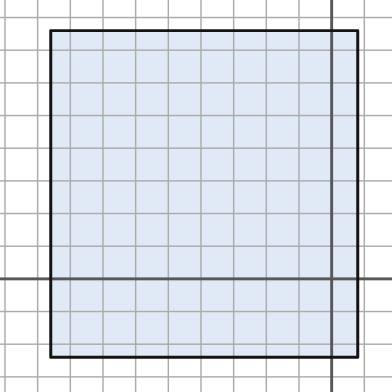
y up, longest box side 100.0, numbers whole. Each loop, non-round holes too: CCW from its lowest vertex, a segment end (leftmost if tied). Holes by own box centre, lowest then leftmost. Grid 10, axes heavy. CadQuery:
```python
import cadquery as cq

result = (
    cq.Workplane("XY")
    .moveTo(-86.0, -24.0)
    .lineTo(8.0, -24.0)
    .lineTo(8.0, 76.0)
    .lineTo(-86.0, 76.0)
    .close()
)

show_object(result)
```